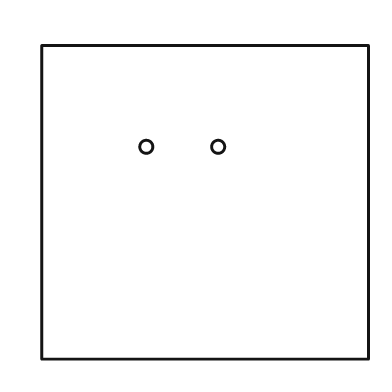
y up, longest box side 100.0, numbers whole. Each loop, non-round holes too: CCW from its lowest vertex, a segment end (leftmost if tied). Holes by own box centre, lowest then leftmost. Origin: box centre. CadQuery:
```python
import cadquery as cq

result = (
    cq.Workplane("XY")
    .moveTo(-50.0, -48.0)
    .lineTo(50.0, -48.0)
    .lineTo(50.0, 48.0)
    .lineTo(-50.0, 48.0)
    .close()
    .moveTo(-18.0, 17.0)
    .circle(2.0)
    .moveTo(4.0, 17.0)
    .circle(2.0)
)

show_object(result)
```